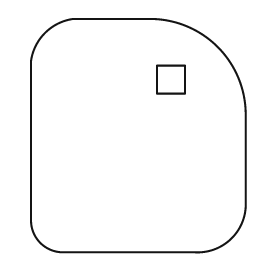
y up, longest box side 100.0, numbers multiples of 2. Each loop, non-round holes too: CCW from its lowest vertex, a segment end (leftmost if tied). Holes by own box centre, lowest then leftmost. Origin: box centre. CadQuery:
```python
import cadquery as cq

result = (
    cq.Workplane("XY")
    .moveTo(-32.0, -50.0)
    .lineTo(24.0, -50.0)
    .threePointArc((40.0, -44.0), (46.0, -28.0))
    .lineTo(46.0, 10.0)
    .threePointArc((34.0, 38.0), (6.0, 50.0))
    .lineTo(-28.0, 50.0)
    .threePointArc((-40.0, 44.0), (-46.0, 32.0))
    .lineTo(-46.0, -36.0)
    .threePointArc((-42.0, -46.0), (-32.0, -50.0))
    .close()
    .moveTo(8.0, 18.0)
    .lineTo(20.0, 18.0)
    .lineTo(20.0, 30.0)
    .lineTo(8.0, 30.0)
    .close()
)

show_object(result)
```